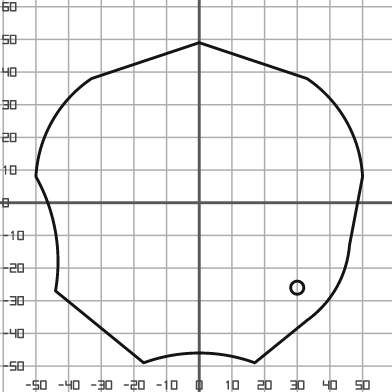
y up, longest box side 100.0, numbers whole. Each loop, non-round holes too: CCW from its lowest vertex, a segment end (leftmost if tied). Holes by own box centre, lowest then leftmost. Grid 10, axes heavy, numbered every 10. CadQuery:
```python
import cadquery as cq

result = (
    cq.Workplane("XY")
    .moveTo(-17.0, -49.0)
    .threePointArc((0.0, -46.0), (17.0, -49.0))
    .lineTo(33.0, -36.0)
    .threePointArc((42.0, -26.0), (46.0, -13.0))
    .lineTo(50.0, 8.0)
    .threePointArc((45.0, 25.0), (33.0, 38.0))
    .lineTo(0.0, 49.0)
    .lineTo(-33.0, 38.0)
    .threePointArc((-45.0, 25.0), (-50.0, 8.0))
    .threePointArc((-44.0, -9.0), (-44.0, -27.0))
    .close()
    .moveTo(30.0, -26.0)
    .circle(2.0)
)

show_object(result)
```